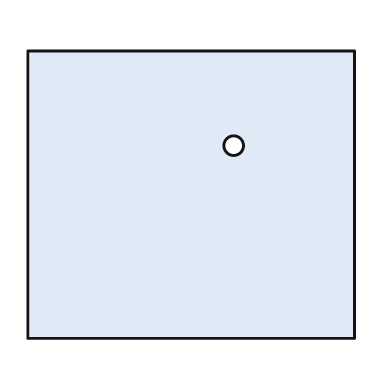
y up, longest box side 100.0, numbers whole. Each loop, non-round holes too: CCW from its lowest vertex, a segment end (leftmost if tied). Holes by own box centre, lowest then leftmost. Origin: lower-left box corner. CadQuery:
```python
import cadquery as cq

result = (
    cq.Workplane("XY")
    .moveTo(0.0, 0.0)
    .lineTo(100.0, 0.0)
    .lineTo(100.0, 88.0)
    .lineTo(0.0, 88.0)
    .close()
    .moveTo(63.0, 59.0)
    .circle(3.0)
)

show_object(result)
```